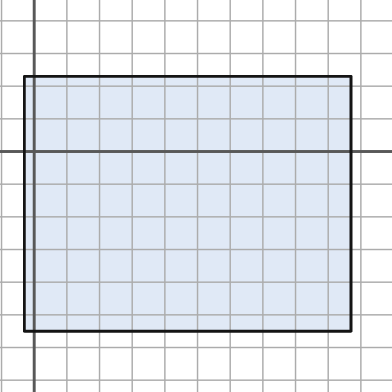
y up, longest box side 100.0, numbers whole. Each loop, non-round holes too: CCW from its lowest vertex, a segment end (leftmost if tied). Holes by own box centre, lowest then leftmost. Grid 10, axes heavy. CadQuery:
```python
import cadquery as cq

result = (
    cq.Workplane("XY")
    .moveTo(-3.0, -55.0)
    .lineTo(97.0, -55.0)
    .lineTo(97.0, 23.0)
    .lineTo(-3.0, 23.0)
    .close()
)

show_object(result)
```